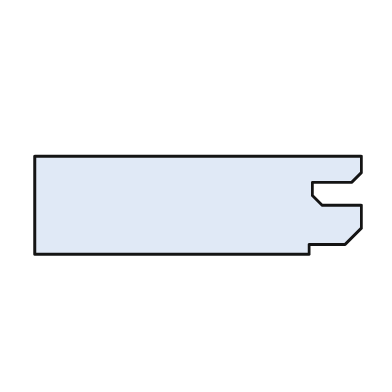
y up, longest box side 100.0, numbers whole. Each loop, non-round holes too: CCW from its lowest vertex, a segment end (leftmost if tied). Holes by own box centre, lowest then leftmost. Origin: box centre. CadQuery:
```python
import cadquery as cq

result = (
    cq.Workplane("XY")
    .moveTo(-50.0, -15.0)
    .lineTo(34.0, -15.0)
    .lineTo(34.0, -12.0)
    .lineTo(45.0, -12.0)
    .lineTo(50.0, -7.0)
    .lineTo(50.0, 0.0)
    .lineTo(38.0, 0.0)
    .lineTo(35.0, 3.0)
    .lineTo(35.0, 7.0)
    .lineTo(47.0, 7.0)
    .lineTo(50.0, 10.0)
    .lineTo(50.0, 15.0)
    .lineTo(-50.0, 15.0)
    .close()
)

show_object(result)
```